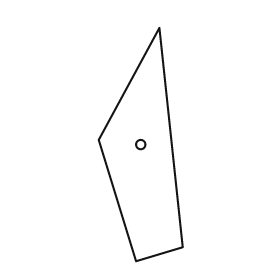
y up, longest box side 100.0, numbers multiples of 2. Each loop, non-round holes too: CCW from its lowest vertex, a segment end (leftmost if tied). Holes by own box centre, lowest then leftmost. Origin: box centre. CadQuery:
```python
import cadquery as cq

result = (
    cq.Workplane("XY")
    .moveTo(-2.0, -50.0)
    .lineTo(18.0, -44.0)
    .lineTo(8.0, 50.0)
    .lineTo(-18.0, 2.0)
    .close()
    .moveTo(0.0, 0.0)
    .circle(2.0)
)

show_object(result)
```